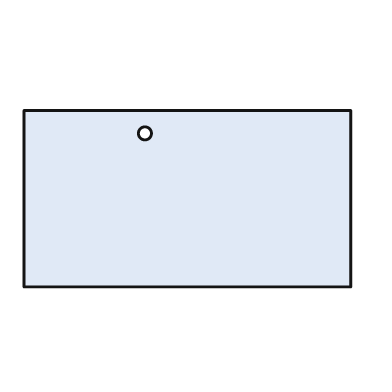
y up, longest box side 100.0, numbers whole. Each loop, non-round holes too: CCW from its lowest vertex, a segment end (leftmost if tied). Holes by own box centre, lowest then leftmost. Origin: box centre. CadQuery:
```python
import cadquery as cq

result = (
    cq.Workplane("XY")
    .moveTo(-50.0, -27.0)
    .lineTo(50.0, -27.0)
    .lineTo(50.0, 27.0)
    .lineTo(-50.0, 27.0)
    .close()
    .moveTo(-13.0, 20.0)
    .circle(2.0)
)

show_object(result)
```